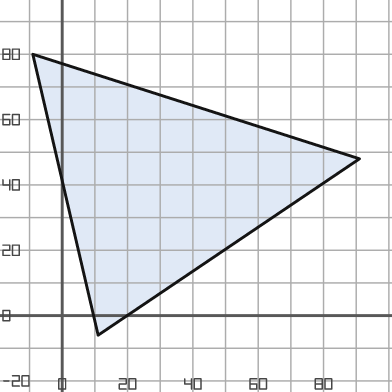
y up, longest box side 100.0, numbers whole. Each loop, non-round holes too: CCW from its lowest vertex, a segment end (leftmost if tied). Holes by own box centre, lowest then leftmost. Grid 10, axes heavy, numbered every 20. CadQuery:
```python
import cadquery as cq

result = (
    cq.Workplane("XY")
    .moveTo(11.0, -6.0)
    .lineTo(91.0, 48.0)
    .lineTo(-9.0, 80.0)
    .close()
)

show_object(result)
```